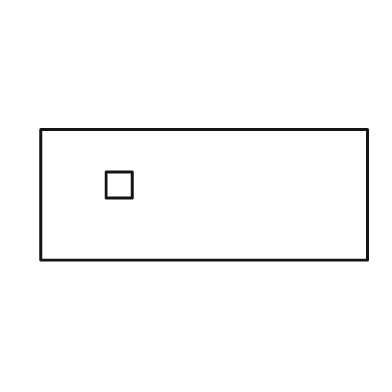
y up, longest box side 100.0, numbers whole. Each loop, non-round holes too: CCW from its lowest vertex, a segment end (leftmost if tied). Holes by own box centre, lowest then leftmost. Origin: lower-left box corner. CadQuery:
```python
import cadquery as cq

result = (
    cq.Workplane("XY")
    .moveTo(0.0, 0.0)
    .lineTo(100.0, 0.0)
    .lineTo(100.0, 40.0)
    .lineTo(0.0, 40.0)
    .close()
    .moveTo(20.0, 19.0)
    .lineTo(28.0, 19.0)
    .lineTo(28.0, 27.0)
    .lineTo(20.0, 27.0)
    .close()
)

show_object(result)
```